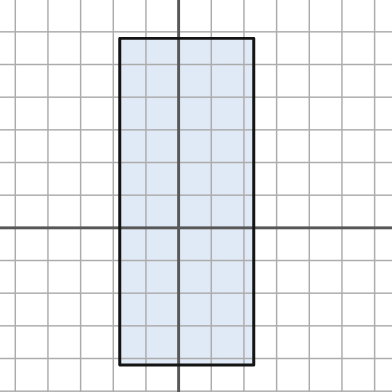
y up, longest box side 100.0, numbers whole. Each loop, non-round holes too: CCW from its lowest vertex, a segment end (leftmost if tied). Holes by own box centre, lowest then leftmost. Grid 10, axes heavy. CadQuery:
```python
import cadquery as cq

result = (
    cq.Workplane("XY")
    .moveTo(-18.0, -42.0)
    .lineTo(23.0, -42.0)
    .lineTo(23.0, 58.0)
    .lineTo(-18.0, 58.0)
    .close()
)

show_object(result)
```